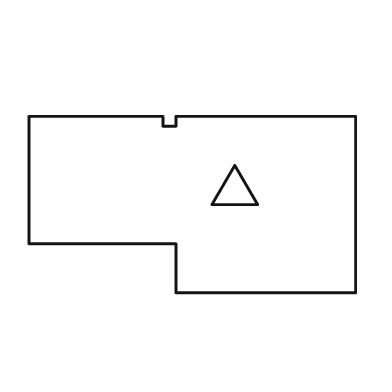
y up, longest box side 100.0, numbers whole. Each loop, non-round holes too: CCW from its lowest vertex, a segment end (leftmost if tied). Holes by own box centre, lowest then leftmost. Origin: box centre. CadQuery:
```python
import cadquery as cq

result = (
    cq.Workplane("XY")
    .moveTo(-5.0, -27.0)
    .lineTo(50.0, -27.0)
    .lineTo(50.0, 27.0)
    .lineTo(-5.0, 27.0)
    .lineTo(-5.0, 24.0)
    .lineTo(-9.0, 24.0)
    .lineTo(-9.0, 27.0)
    .lineTo(-50.0, 27.0)
    .lineTo(-50.0, -12.0)
    .lineTo(-5.0, -12.0)
    .close()
    .moveTo(6.0, 0.0)
    .lineTo(20.0, 0.0)
    .lineTo(13.0, 12.0)
    .close()
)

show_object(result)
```